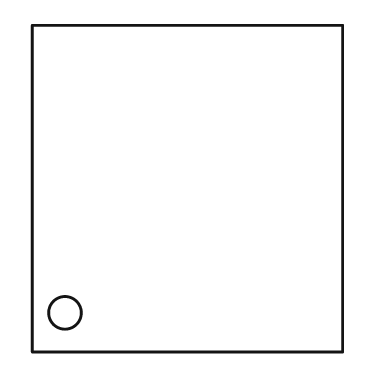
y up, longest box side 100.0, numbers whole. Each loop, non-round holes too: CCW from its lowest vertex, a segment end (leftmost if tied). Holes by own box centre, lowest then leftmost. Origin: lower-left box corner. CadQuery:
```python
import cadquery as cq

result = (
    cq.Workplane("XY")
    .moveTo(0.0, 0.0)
    .lineTo(95.0, 0.0)
    .lineTo(95.0, 100.0)
    .lineTo(0.0, 100.0)
    .close()
    .moveTo(10.0, 12.0)
    .circle(5.0)
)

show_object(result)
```